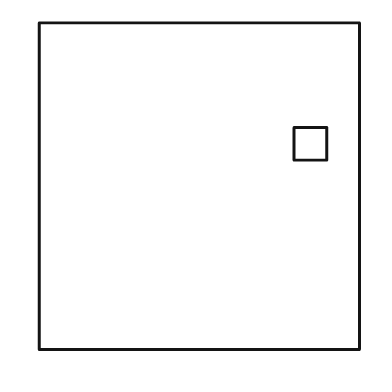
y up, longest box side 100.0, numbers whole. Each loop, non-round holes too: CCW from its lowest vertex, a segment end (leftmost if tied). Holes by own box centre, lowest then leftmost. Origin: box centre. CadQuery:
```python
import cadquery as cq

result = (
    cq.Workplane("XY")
    .moveTo(-49.0, -50.0)
    .lineTo(49.0, -50.0)
    .lineTo(49.0, 50.0)
    .lineTo(-49.0, 50.0)
    .close()
    .moveTo(29.0, 8.0)
    .lineTo(39.0, 8.0)
    .lineTo(39.0, 18.0)
    .lineTo(29.0, 18.0)
    .close()
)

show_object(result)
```